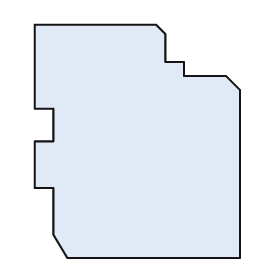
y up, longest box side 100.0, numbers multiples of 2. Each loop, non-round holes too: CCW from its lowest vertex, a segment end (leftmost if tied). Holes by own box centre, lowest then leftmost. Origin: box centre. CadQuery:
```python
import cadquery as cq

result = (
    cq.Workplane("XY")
    .moveTo(-30.0, -50.0)
    .lineTo(44.0, -50.0)
    .lineTo(44.0, 22.0)
    .lineTo(38.0, 28.0)
    .lineTo(20.0, 28.0)
    .lineTo(20.0, 34.0)
    .lineTo(12.0, 34.0)
    .lineTo(12.0, 46.0)
    .lineTo(8.0, 50.0)
    .lineTo(-44.0, 50.0)
    .lineTo(-44.0, 14.0)
    .lineTo(-36.0, 14.0)
    .lineTo(-36.0, 0.0)
    .lineTo(-44.0, 0.0)
    .lineTo(-44.0, -20.0)
    .lineTo(-36.0, -20.0)
    .lineTo(-36.0, -40.0)
    .close()
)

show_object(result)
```